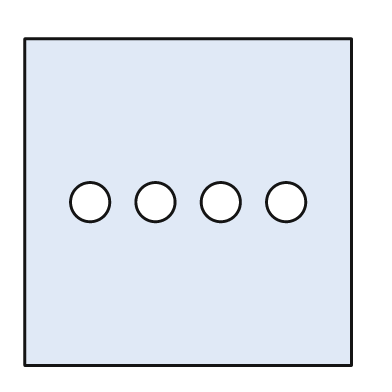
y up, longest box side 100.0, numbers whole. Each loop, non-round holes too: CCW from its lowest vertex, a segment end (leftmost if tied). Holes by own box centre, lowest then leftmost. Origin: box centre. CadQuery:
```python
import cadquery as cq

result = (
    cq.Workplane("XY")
    .moveTo(-50.0, -50.0)
    .lineTo(50.0, -50.0)
    .lineTo(50.0, 50.0)
    .lineTo(-50.0, 50.0)
    .close()
    .moveTo(-30.0, 0.0)
    .circle(6.0)
    .moveTo(-10.0, 0.0)
    .circle(6.0)
    .moveTo(10.0, 0.0)
    .circle(6.0)
    .moveTo(30.0, 0.0)
    .circle(6.0)
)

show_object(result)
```